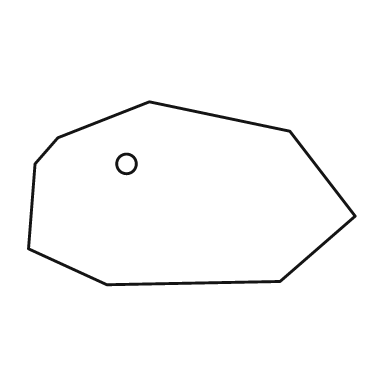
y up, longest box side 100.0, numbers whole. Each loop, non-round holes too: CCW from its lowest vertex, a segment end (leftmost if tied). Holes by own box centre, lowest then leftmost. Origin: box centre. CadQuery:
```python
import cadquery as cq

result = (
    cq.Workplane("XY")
    .moveTo(-26.0, -28.0)
    .lineTo(27.0, -27.0)
    .lineTo(50.0, -7.0)
    .lineTo(30.0, 19.0)
    .lineTo(-13.0, 28.0)
    .lineTo(-41.0, 17.0)
    .lineTo(-48.0, 9.0)
    .lineTo(-50.0, -17.0)
    .close()
    .moveTo(-20.0, 9.0)
    .circle(3.0)
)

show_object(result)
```